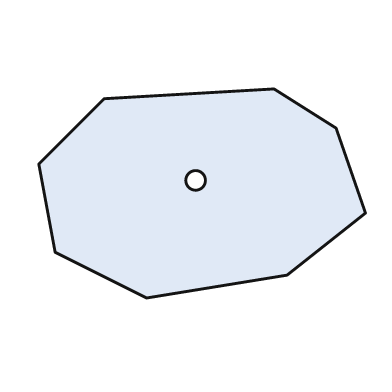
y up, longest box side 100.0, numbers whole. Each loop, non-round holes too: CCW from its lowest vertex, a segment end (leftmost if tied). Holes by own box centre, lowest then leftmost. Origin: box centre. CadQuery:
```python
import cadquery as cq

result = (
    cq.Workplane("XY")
    .moveTo(-17.0, -32.0)
    .lineTo(26.0, -25.0)
    .lineTo(50.0, -6.0)
    .lineTo(41.0, 20.0)
    .lineTo(22.0, 32.0)
    .lineTo(-30.0, 29.0)
    .lineTo(-50.0, 9.0)
    .lineTo(-45.0, -18.0)
    .close()
    .moveTo(-2.0, 4.0)
    .circle(3.0)
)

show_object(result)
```